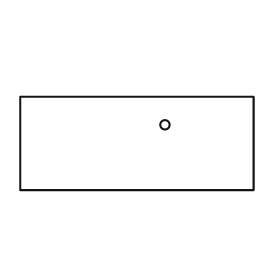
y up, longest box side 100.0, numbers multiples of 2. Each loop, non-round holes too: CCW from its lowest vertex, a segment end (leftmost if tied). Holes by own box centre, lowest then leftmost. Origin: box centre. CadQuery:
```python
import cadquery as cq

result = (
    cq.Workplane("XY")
    .moveTo(-50.0, -20.0)
    .lineTo(50.0, -20.0)
    .lineTo(50.0, 20.0)
    .lineTo(-50.0, 20.0)
    .close()
    .moveTo(12.0, 8.0)
    .circle(2.0)
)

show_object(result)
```